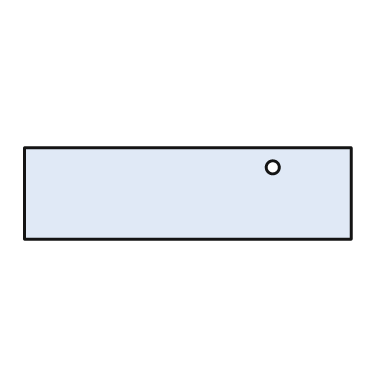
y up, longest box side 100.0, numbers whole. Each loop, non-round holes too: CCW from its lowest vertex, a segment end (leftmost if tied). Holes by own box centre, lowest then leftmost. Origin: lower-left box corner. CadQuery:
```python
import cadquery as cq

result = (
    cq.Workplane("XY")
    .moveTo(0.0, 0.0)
    .lineTo(100.0, 0.0)
    .lineTo(100.0, 28.0)
    .lineTo(0.0, 28.0)
    .close()
    .moveTo(76.0, 22.0)
    .circle(2.0)
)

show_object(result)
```